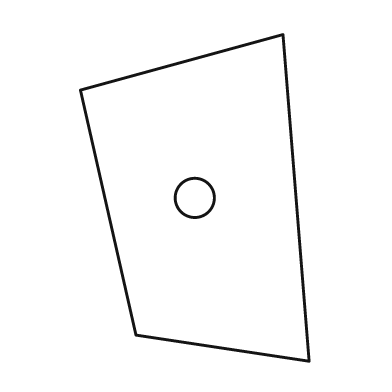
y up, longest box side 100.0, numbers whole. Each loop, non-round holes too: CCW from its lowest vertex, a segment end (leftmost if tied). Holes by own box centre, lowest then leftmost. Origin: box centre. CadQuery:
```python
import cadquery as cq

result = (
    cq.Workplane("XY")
    .moveTo(35.0, -50.0)
    .lineTo(27.0, 50.0)
    .lineTo(-35.0, 33.0)
    .lineTo(-18.0, -42.0)
    .close()
    .moveTo(0.0, 0.0)
    .circle(6.0)
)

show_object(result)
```